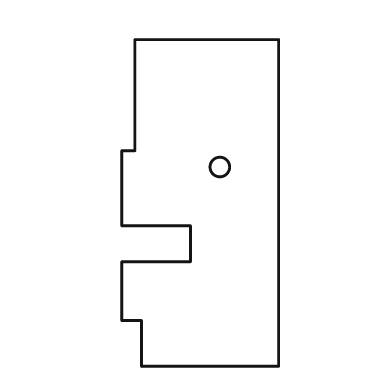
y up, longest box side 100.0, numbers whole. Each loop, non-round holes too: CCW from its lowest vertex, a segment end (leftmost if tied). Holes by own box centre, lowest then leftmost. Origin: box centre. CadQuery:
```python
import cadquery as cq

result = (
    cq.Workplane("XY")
    .moveTo(-18.0, -50.0)
    .lineTo(24.0, -50.0)
    .lineTo(24.0, 50.0)
    .lineTo(-20.0, 50.0)
    .lineTo(-20.0, 16.0)
    .lineTo(-24.0, 16.0)
    .lineTo(-24.0, -7.0)
    .lineTo(-3.0, -7.0)
    .lineTo(-3.0, -18.0)
    .lineTo(-24.0, -18.0)
    .lineTo(-24.0, -36.0)
    .lineTo(-18.0, -36.0)
    .close()
    .moveTo(6.0, 11.0)
    .circle(3.0)
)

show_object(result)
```